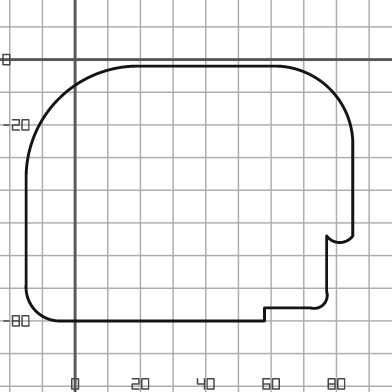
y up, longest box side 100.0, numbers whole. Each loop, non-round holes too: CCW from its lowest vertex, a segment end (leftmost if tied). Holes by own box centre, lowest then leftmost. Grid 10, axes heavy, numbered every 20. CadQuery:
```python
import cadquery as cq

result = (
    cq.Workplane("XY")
    .moveTo(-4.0, -80.0)
    .lineTo(58.0, -80.0)
    .lineTo(58.0, -76.0)
    .lineTo(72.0, -76.0)
    .threePointArc((76.0, -75.0), (77.0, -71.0))
    .lineTo(77.0, -54.0)
    .threePointArc((81.0, -56.0), (85.0, -54.0))
    .lineTo(85.0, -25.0)
    .threePointArc((78.0, -9.0), (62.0, -2.0))
    .lineTo(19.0, -2.0)
    .threePointArc((-5.0, -12.0), (-15.0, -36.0))
    .lineTo(-15.0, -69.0)
    .threePointArc((-12.0, -77.0), (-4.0, -80.0))
    .close()
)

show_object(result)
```